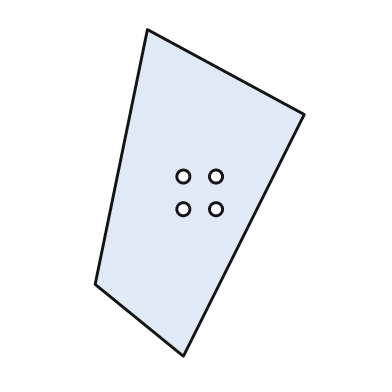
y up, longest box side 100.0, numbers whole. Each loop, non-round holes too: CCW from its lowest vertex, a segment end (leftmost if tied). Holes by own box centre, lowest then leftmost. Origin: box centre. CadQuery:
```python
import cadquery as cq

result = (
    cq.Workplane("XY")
    .moveTo(-5.0, -50.0)
    .lineTo(32.0, 24.0)
    .lineTo(-16.0, 50.0)
    .lineTo(-32.0, -28.0)
    .close()
    .moveTo(-5.0, -5.0)
    .circle(2.0)
    .moveTo(5.0, -5.0)
    .circle(2.0)
    .moveTo(-5.0, 5.0)
    .circle(2.0)
    .moveTo(5.0, 5.0)
    .circle(2.0)
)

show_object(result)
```